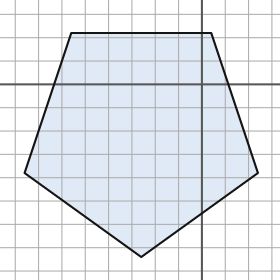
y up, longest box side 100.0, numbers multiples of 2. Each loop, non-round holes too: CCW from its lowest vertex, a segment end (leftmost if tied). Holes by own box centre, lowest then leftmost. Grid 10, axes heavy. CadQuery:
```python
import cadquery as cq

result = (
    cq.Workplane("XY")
    .moveTo(-26.0, -74.0)
    .lineTo(24.0, -38.0)
    .lineTo(4.0, 22.0)
    .lineTo(-56.0, 22.0)
    .lineTo(-76.0, -38.0)
    .close()
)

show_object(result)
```